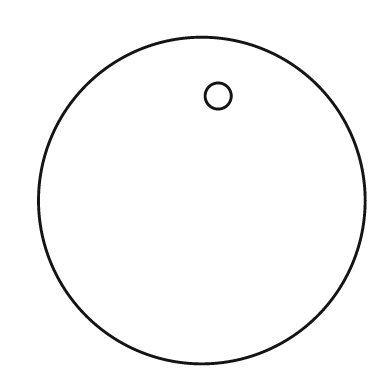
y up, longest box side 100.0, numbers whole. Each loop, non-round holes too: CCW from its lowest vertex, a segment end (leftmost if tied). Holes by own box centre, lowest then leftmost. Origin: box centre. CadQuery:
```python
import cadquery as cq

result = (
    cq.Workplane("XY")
    .moveTo(0.0, 0.0)
    .circle(50.0)
    .moveTo(5.0, 32.0)
    .circle(4.0)
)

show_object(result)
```